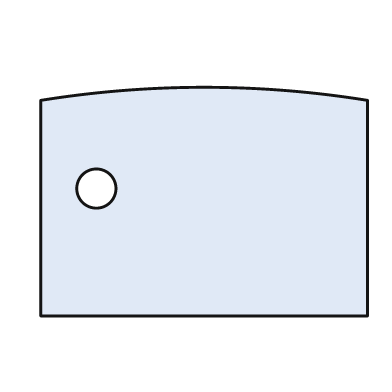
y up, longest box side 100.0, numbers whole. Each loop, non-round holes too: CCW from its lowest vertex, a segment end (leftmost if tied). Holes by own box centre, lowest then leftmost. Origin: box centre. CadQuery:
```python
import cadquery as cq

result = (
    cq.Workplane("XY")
    .moveTo(-50.0, -35.0)
    .lineTo(50.0, -35.0)
    .lineTo(50.0, 31.0)
    .threePointArc((0.0, 35.0), (-50.0, 31.0))
    .close()
    .moveTo(-33.0, 4.0)
    .circle(6.0)
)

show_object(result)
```